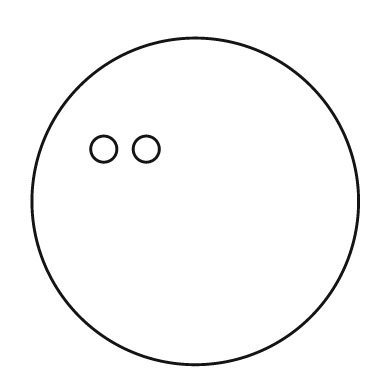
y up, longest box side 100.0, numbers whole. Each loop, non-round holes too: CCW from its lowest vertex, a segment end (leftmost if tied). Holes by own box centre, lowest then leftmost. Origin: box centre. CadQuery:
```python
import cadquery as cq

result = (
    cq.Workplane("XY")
    .moveTo(0.0, 0.0)
    .circle(50.0)
    .moveTo(-28.0, 16.0)
    .circle(4.0)
    .moveTo(-15.0, 16.0)
    .circle(4.0)
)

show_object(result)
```